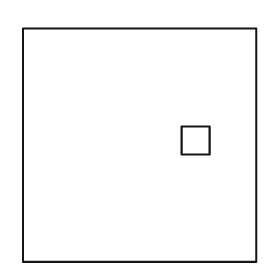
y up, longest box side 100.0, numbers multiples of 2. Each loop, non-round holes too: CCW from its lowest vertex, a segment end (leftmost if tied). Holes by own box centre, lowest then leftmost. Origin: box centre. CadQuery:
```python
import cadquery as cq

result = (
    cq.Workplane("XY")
    .moveTo(-50.0, -50.0)
    .lineTo(50.0, -50.0)
    .lineTo(50.0, 50.0)
    .lineTo(-50.0, 50.0)
    .close()
    .moveTo(18.0, -4.0)
    .lineTo(30.0, -4.0)
    .lineTo(30.0, 8.0)
    .lineTo(18.0, 8.0)
    .close()
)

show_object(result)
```